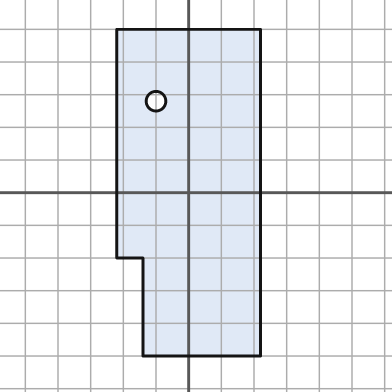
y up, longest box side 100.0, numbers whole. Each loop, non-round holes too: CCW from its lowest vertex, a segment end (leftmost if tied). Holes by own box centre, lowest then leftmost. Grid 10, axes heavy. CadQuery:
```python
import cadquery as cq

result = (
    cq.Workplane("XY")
    .moveTo(-14.0, -50.0)
    .lineTo(22.0, -50.0)
    .lineTo(22.0, 50.0)
    .lineTo(-22.0, 50.0)
    .lineTo(-22.0, -20.0)
    .lineTo(-14.0, -20.0)
    .close()
    .moveTo(-10.0, 28.0)
    .circle(3.0)
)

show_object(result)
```